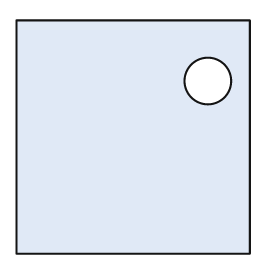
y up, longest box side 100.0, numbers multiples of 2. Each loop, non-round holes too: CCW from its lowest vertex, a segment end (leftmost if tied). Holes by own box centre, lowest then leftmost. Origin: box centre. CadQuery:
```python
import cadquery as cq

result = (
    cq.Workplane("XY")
    .moveTo(-50.0, -50.0)
    .lineTo(50.0, -50.0)
    .lineTo(50.0, 50.0)
    .lineTo(-50.0, 50.0)
    .close()
    .moveTo(32.0, 24.0)
    .circle(10.0)
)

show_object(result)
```